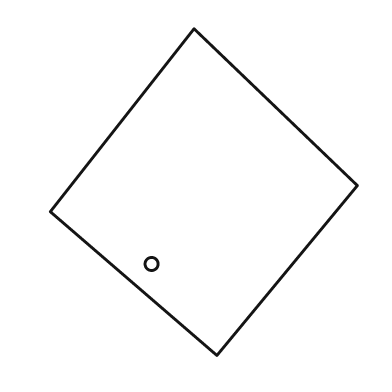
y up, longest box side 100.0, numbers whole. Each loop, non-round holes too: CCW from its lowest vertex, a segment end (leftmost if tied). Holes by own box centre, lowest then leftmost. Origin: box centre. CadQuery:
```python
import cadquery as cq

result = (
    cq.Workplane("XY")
    .moveTo(4.0, -50.0)
    .lineTo(47.0, 2.0)
    .lineTo(-3.0, 50.0)
    .lineTo(-47.0, -6.0)
    .close()
    .moveTo(-16.0, -22.0)
    .circle(2.0)
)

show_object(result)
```